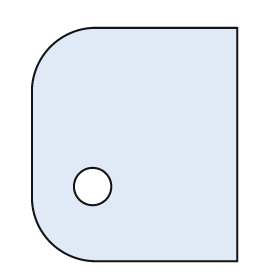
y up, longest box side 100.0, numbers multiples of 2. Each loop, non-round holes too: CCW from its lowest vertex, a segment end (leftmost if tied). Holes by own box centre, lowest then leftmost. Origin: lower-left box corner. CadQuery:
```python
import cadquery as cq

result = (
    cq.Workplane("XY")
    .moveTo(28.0, 0.0)
    .lineTo(88.0, 0.0)
    .lineTo(88.0, 100.0)
    .lineTo(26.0, 100.0)
    .threePointArc((8.0, 92.0), (0.0, 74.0))
    .lineTo(0.0, 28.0)
    .threePointArc((8.0, 8.0), (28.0, 0.0))
    .close()
    .moveTo(26.0, 32.0)
    .circle(8.0)
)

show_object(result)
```